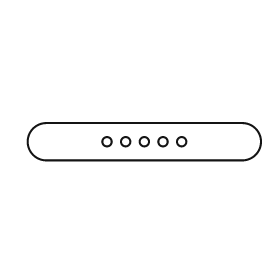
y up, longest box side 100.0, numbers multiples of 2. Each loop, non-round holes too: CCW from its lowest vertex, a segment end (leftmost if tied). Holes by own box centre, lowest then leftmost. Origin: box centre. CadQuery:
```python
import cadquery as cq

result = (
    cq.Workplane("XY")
    .moveTo(-42.0, -8.0)
    .lineTo(42.0, -8.0)
    .threePointArc((50.0, 0.0), (42.0, 8.0))
    .lineTo(-42.0, 8.0)
    .threePointArc((-50.0, 0.0), (-42.0, -8.0))
    .close()
    .moveTo(-16.0, 0.0)
    .circle(2.0)
    .moveTo(-8.0, 0.0)
    .circle(2.0)
    .moveTo(0.0, 0.0)
    .circle(2.0)
    .moveTo(8.0, 0.0)
    .circle(2.0)
    .moveTo(16.0, 0.0)
    .circle(2.0)
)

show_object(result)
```